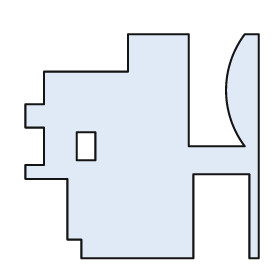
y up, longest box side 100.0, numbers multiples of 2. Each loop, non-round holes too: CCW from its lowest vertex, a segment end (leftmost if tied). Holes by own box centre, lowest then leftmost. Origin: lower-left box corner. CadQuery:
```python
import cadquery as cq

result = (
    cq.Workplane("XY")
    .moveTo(24.0, 0.0)
    .lineTo(72.0, 0.0)
    .lineTo(72.0, 36.0)
    .lineTo(96.0, 36.0)
    .lineTo(96.0, 0.0)
    .lineTo(100.0, 0.0)
    .lineTo(100.0, 96.0)
    .lineTo(94.0, 96.0)
    .threePointArc((86.0, 72.0), (94.0, 48.0))
    .lineTo(70.0, 48.0)
    .lineTo(70.0, 96.0)
    .lineTo(44.0, 96.0)
    .lineTo(44.0, 80.0)
    .lineTo(8.0, 80.0)
    .lineTo(8.0, 66.0)
    .lineTo(0.0, 66.0)
    .lineTo(0.0, 56.0)
    .lineTo(8.0, 56.0)
    .lineTo(8.0, 40.0)
    .lineTo(0.0, 40.0)
    .lineTo(0.0, 34.0)
    .lineTo(18.0, 34.0)
    .lineTo(18.0, 8.0)
    .lineTo(24.0, 8.0)
    .close()
    .moveTo(22.0, 42.0)
    .lineTo(30.0, 42.0)
    .lineTo(30.0, 54.0)
    .lineTo(22.0, 54.0)
    .close()
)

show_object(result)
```